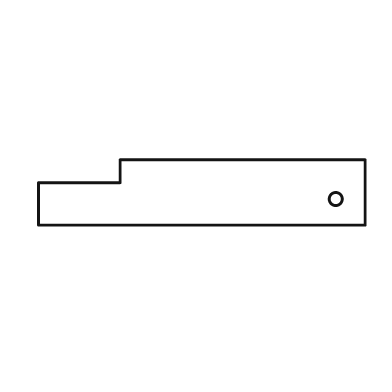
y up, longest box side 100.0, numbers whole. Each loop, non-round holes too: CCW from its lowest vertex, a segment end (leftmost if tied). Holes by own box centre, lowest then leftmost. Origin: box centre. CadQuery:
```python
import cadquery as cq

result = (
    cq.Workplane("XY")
    .moveTo(-50.0, -10.0)
    .lineTo(50.0, -10.0)
    .lineTo(50.0, 10.0)
    .lineTo(-25.0, 10.0)
    .lineTo(-25.0, 3.0)
    .lineTo(-50.0, 3.0)
    .close()
    .moveTo(41.0, -2.0)
    .circle(2.0)
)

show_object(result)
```